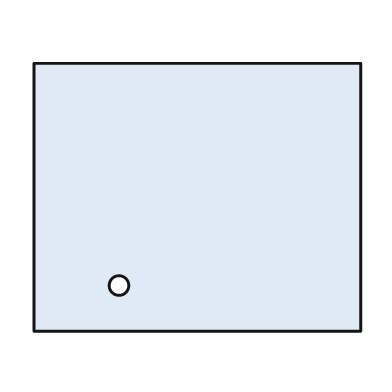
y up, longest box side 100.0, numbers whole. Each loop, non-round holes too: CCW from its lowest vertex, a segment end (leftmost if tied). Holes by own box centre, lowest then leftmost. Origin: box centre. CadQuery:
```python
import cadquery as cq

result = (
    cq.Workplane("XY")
    .moveTo(-50.0, -41.0)
    .lineTo(50.0, -41.0)
    .lineTo(50.0, 41.0)
    .lineTo(-50.0, 41.0)
    .close()
    .moveTo(-24.0, -27.0)
    .circle(3.0)
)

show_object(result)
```